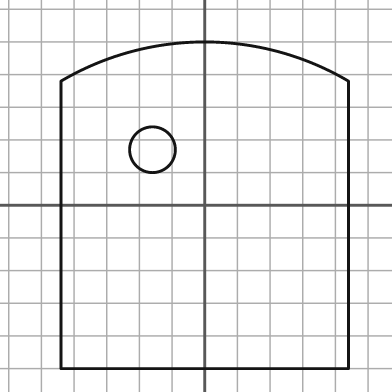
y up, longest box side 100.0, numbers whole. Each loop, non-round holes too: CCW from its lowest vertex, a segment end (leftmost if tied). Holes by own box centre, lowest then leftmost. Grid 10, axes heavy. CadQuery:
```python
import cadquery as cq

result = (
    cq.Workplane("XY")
    .moveTo(-44.0, -50.0)
    .lineTo(44.0, -50.0)
    .lineTo(44.0, 38.0)
    .threePointArc((0.0, 50.0), (-44.0, 38.0))
    .close()
    .moveTo(-16.0, 17.0)
    .circle(7.0)
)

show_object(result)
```